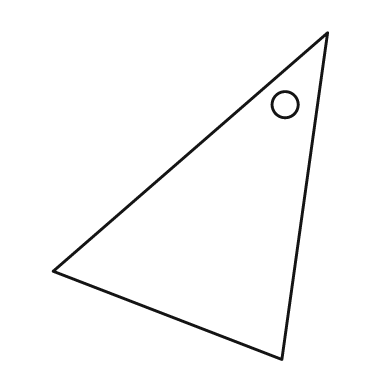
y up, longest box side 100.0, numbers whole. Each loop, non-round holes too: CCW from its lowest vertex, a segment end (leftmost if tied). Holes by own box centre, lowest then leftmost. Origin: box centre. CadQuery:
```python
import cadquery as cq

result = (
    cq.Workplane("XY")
    .moveTo(28.0, -50.0)
    .lineTo(42.0, 50.0)
    .lineTo(-42.0, -23.0)
    .close()
    .moveTo(29.0, 28.0)
    .circle(4.0)
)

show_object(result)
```